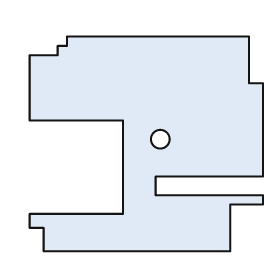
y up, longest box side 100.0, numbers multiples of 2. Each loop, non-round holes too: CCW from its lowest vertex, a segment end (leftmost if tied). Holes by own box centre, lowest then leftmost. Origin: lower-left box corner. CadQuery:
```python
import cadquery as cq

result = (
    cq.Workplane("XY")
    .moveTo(6.0, 0.0)
    .lineTo(86.0, 0.0)
    .lineTo(86.0, 20.0)
    .lineTo(100.0, 20.0)
    .lineTo(100.0, 24.0)
    .lineTo(54.0, 24.0)
    .lineTo(54.0, 32.0)
    .lineTo(100.0, 32.0)
    .lineTo(100.0, 72.0)
    .lineTo(94.0, 72.0)
    .lineTo(94.0, 92.0)
    .lineTo(16.0, 92.0)
    .lineTo(16.0, 88.0)
    .lineTo(12.0, 88.0)
    .lineTo(12.0, 84.0)
    .lineTo(0.0, 84.0)
    .lineTo(0.0, 56.0)
    .lineTo(40.0, 56.0)
    .lineTo(40.0, 16.0)
    .lineTo(0.0, 16.0)
    .lineTo(0.0, 10.0)
    .lineTo(6.0, 10.0)
    .close()
    .moveTo(56.0, 48.0)
    .circle(4.0)
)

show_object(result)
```